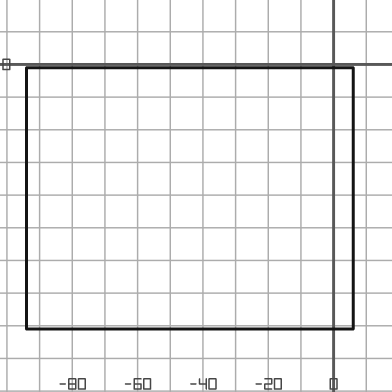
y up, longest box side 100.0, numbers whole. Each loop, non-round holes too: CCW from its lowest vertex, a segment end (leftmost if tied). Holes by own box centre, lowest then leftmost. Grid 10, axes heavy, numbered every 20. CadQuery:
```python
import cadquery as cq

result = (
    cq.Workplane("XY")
    .moveTo(-94.0, -81.0)
    .lineTo(6.0, -81.0)
    .lineTo(6.0, -1.0)
    .lineTo(-94.0, -1.0)
    .close()
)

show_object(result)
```